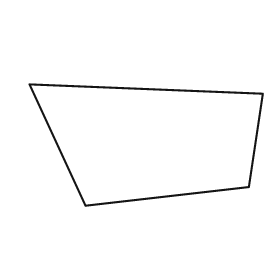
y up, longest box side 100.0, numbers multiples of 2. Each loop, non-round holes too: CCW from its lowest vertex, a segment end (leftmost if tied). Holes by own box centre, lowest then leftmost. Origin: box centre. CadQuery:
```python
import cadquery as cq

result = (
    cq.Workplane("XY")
    .moveTo(-26.0, -26.0)
    .lineTo(44.0, -18.0)
    .lineTo(50.0, 22.0)
    .lineTo(-50.0, 26.0)
    .close()
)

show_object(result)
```